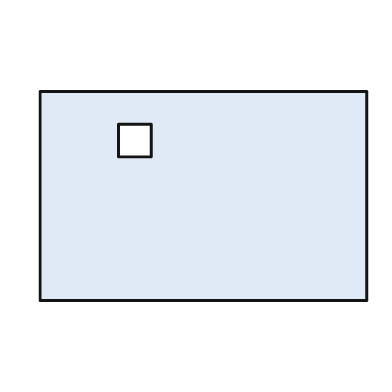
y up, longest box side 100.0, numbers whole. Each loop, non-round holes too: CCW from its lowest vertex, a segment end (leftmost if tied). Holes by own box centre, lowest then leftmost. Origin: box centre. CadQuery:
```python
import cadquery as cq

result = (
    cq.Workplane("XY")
    .moveTo(-50.0, -32.0)
    .lineTo(50.0, -32.0)
    .lineTo(50.0, 32.0)
    .lineTo(-50.0, 32.0)
    .close()
    .moveTo(-26.0, 12.0)
    .lineTo(-16.0, 12.0)
    .lineTo(-16.0, 22.0)
    .lineTo(-26.0, 22.0)
    .close()
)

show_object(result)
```